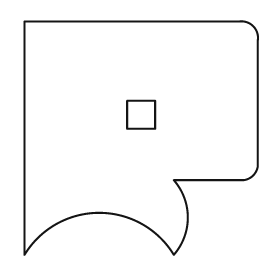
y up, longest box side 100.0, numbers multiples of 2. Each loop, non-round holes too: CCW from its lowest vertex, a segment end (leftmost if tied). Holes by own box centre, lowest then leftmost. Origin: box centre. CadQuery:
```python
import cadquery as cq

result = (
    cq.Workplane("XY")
    .moveTo(-50.0, -50.0)
    .threePointArc((-18.0, -32.0), (14.0, -50.0))
    .threePointArc((20.0, -34.0), (14.0, -18.0))
    .lineTo(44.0, -18.0)
    .threePointArc((48.0, -16.0), (50.0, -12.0))
    .lineTo(50.0, 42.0)
    .threePointArc((48.0, 48.0), (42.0, 50.0))
    .lineTo(-50.0, 50.0)
    .close()
    .moveTo(-6.0, 4.0)
    .lineTo(6.0, 4.0)
    .lineTo(6.0, 16.0)
    .lineTo(-6.0, 16.0)
    .close()
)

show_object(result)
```